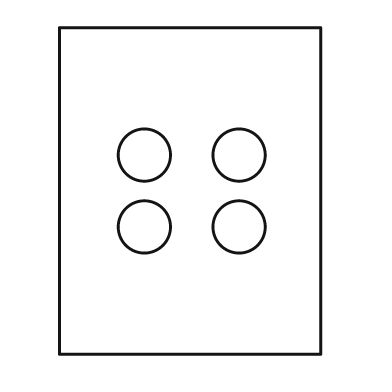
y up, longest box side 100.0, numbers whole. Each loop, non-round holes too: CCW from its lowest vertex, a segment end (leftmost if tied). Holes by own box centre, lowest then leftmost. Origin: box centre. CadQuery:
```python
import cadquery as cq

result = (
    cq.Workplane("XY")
    .moveTo(-40.0, -50.0)
    .lineTo(40.0, -50.0)
    .lineTo(40.0, 50.0)
    .lineTo(-40.0, 50.0)
    .close()
    .moveTo(-14.0, -11.0)
    .circle(8.0)
    .moveTo(15.0, -11.0)
    .circle(8.0)
    .moveTo(-14.0, 11.0)
    .circle(8.0)
    .moveTo(15.0, 11.0)
    .circle(8.0)
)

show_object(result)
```